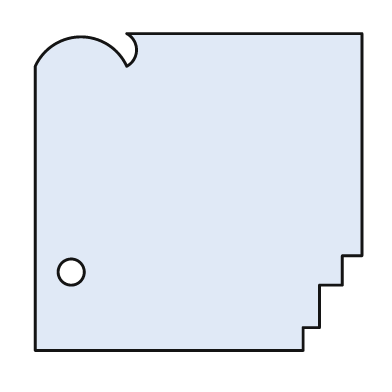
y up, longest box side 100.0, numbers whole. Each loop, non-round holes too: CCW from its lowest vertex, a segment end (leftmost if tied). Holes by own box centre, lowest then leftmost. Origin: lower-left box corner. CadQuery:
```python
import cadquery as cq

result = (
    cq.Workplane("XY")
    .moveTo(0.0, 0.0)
    .lineTo(82.0, 0.0)
    .lineTo(82.0, 7.0)
    .lineTo(87.0, 7.0)
    .lineTo(87.0, 20.0)
    .lineTo(94.0, 20.0)
    .lineTo(94.0, 29.0)
    .lineTo(100.0, 29.0)
    .lineTo(100.0, 97.0)
    .lineTo(28.0, 97.0)
    .threePointArc((31.0, 92.0), (28.0, 87.0))
    .threePointArc((14.0, 96.0), (0.0, 87.0))
    .close()
    .moveTo(11.0, 24.0)
    .circle(4.0)
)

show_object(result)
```